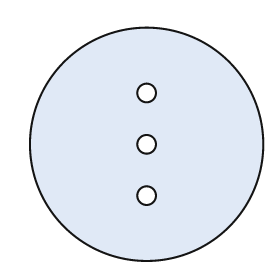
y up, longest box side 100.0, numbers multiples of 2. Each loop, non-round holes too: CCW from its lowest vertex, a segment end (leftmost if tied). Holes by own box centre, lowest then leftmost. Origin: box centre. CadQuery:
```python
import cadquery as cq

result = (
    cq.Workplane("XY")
    .moveTo(0.0, 0.0)
    .circle(50.0)
    .moveTo(0.0, -22.0)
    .circle(4.0)
    .moveTo(0.0, 0.0)
    .circle(4.0)
    .moveTo(0.0, 22.0)
    .circle(4.0)
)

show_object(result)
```